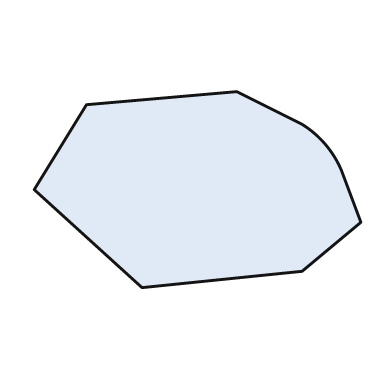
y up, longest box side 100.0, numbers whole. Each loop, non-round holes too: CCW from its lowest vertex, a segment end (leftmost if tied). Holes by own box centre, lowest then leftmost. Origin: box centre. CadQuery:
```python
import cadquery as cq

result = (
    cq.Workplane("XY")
    .moveTo(-17.0, -30.0)
    .lineTo(32.0, -25.0)
    .lineTo(50.0, -10.0)
    .lineTo(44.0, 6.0)
    .threePointArc((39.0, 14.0), (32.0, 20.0))
    .lineTo(12.0, 30.0)
    .lineTo(-34.0, 26.0)
    .lineTo(-50.0, 0.0)
    .close()
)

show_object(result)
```